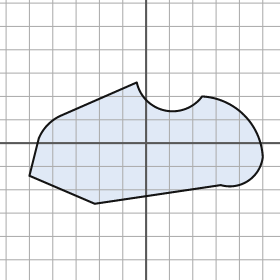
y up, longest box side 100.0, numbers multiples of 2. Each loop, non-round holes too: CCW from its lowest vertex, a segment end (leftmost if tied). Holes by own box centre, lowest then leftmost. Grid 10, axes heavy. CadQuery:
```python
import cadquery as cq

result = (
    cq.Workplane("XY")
    .moveTo(-22.0, -26.0)
    .lineTo(32.0, -18.0)
    .threePointArc((44.0, -16.0), (50.0, -6.0))
    .threePointArc((42.0, 12.0), (24.0, 20.0))
    .threePointArc((8.0, 14.0), (-4.0, 26.0))
    .lineTo(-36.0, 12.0)
    .threePointArc((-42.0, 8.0), (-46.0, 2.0))
    .lineTo(-50.0, -14.0)
    .close()
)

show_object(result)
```